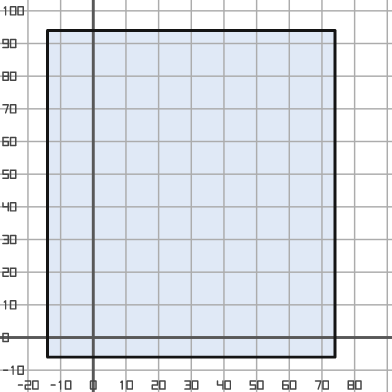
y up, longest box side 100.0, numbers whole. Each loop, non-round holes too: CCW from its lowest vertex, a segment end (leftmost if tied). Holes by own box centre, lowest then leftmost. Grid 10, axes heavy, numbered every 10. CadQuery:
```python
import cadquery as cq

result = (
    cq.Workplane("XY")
    .moveTo(-14.0, -6.0)
    .lineTo(74.0, -6.0)
    .lineTo(74.0, 94.0)
    .lineTo(-14.0, 94.0)
    .close()
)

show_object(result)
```